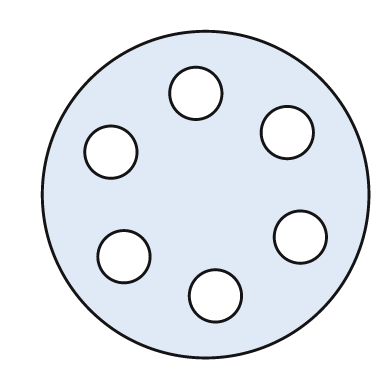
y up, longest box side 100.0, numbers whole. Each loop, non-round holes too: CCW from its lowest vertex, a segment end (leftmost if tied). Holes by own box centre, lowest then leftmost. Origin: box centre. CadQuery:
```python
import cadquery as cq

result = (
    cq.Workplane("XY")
    .moveTo(0.0, 0.0)
    .circle(50.0)
    .moveTo(3.0, -31.0)
    .circle(8.0)
    .moveTo(-25.0, -19.0)
    .circle(8.0)
    .moveTo(29.0, -13.0)
    .circle(8.0)
    .moveTo(-29.0, 13.0)
    .circle(8.0)
    .moveTo(25.0, 19.0)
    .circle(8.0)
    .moveTo(-3.0, 31.0)
    .circle(8.0)
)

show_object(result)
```